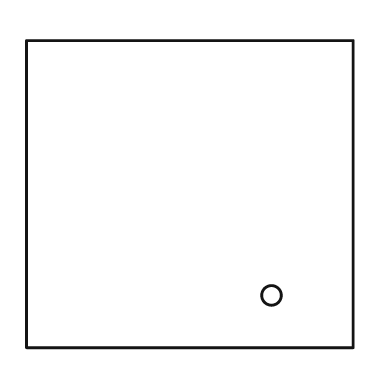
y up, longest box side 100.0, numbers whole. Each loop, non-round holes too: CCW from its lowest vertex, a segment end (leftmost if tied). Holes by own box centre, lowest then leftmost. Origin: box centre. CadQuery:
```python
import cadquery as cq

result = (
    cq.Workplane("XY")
    .moveTo(-50.0, -47.0)
    .lineTo(50.0, -47.0)
    .lineTo(50.0, 47.0)
    .lineTo(-50.0, 47.0)
    .close()
    .moveTo(25.0, -31.0)
    .circle(3.0)
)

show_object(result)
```